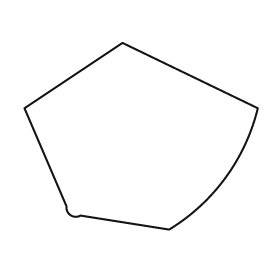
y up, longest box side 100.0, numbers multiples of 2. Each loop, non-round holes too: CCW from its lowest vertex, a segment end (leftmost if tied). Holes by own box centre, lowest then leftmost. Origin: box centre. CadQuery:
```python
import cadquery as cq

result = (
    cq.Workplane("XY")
    .moveTo(12.0, -40.0)
    .threePointArc((36.0, -18.0), (50.0, 12.0))
    .lineTo(-8.0, 40.0)
    .lineTo(-50.0, 12.0)
    .lineTo(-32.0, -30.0)
    .threePointArc((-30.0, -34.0), (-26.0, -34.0))
    .close()
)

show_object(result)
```